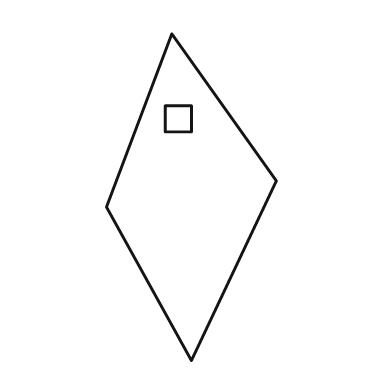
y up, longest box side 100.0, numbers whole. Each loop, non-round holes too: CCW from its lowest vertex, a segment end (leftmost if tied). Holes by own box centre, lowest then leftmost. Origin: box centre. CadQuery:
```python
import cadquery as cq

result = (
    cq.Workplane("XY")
    .moveTo(0.0, -50.0)
    .lineTo(26.0, 5.0)
    .lineTo(-6.0, 50.0)
    .lineTo(-26.0, -3.0)
    .close()
    .moveTo(-8.0, 20.0)
    .lineTo(0.0, 20.0)
    .lineTo(0.0, 28.0)
    .lineTo(-8.0, 28.0)
    .close()
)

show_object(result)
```